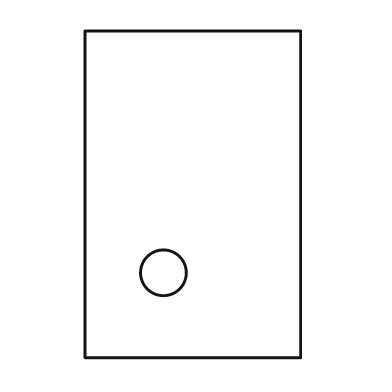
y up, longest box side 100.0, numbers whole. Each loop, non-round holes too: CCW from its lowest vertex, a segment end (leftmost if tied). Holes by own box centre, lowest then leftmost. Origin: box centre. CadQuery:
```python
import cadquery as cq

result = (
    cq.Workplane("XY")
    .moveTo(-33.0, -50.0)
    .lineTo(33.0, -50.0)
    .lineTo(33.0, 50.0)
    .lineTo(-33.0, 50.0)
    .close()
    .moveTo(-9.0, -24.0)
    .circle(7.0)
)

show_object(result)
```